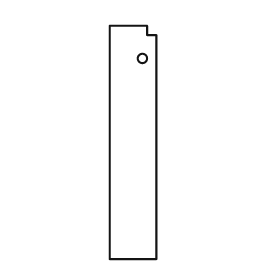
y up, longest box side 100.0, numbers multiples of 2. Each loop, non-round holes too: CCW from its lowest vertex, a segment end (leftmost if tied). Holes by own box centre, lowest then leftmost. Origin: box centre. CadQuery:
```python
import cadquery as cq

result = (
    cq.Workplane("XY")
    .moveTo(-10.0, -50.0)
    .lineTo(10.0, -50.0)
    .lineTo(10.0, 46.0)
    .lineTo(6.0, 46.0)
    .lineTo(6.0, 50.0)
    .lineTo(-10.0, 50.0)
    .close()
    .moveTo(4.0, 36.0)
    .circle(2.0)
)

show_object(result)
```